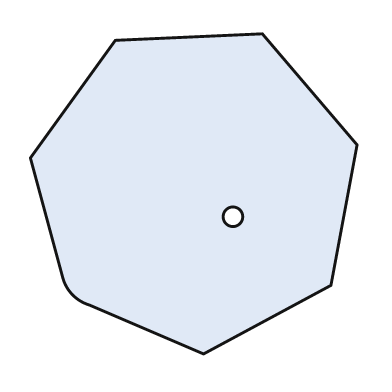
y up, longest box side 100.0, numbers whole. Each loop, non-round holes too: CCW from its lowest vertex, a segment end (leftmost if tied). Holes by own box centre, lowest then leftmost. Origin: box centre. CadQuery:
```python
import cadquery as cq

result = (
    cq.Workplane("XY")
    .moveTo(3.0, -49.0)
    .lineTo(42.0, -28.0)
    .lineTo(50.0, 15.0)
    .lineTo(21.0, 49.0)
    .lineTo(-24.0, 47.0)
    .lineTo(-50.0, 11.0)
    .lineTo(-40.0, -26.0)
    .threePointArc((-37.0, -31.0), (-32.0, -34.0))
    .close()
    .moveTo(12.0, -7.0)
    .circle(3.0)
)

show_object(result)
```